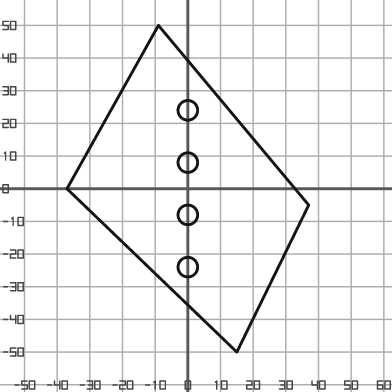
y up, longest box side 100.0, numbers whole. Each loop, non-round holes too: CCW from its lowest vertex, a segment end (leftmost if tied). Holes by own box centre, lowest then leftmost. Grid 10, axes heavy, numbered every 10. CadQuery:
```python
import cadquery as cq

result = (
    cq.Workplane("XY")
    .moveTo(15.0, -50.0)
    .lineTo(37.0, -5.0)
    .lineTo(-9.0, 50.0)
    .lineTo(-37.0, 0.0)
    .close()
    .moveTo(0.0, -24.0)
    .circle(3.0)
    .moveTo(0.0, -8.0)
    .circle(3.0)
    .moveTo(0.0, 8.0)
    .circle(3.0)
    .moveTo(0.0, 24.0)
    .circle(3.0)
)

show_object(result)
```